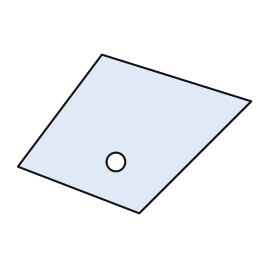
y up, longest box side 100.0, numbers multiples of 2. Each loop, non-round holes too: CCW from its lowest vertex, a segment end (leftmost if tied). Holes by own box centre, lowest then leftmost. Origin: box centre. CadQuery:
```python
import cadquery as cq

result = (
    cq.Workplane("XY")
    .moveTo(2.0, -34.0)
    .lineTo(50.0, 14.0)
    .lineTo(-14.0, 34.0)
    .lineTo(-50.0, -14.0)
    .close()
    .moveTo(-8.0, -12.0)
    .circle(4.0)
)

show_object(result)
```